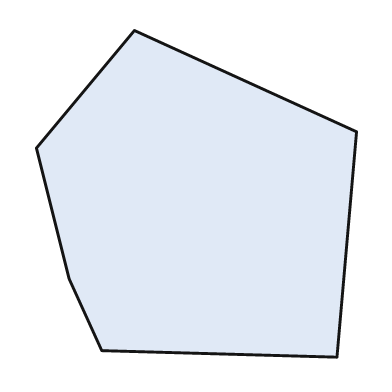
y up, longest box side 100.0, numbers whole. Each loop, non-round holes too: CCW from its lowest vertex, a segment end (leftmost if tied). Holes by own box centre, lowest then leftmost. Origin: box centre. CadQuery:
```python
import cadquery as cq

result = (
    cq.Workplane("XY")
    .moveTo(43.0, -50.0)
    .lineTo(49.0, 19.0)
    .lineTo(-19.0, 50.0)
    .lineTo(-49.0, 14.0)
    .lineTo(-39.0, -26.0)
    .lineTo(-29.0, -48.0)
    .close()
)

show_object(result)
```